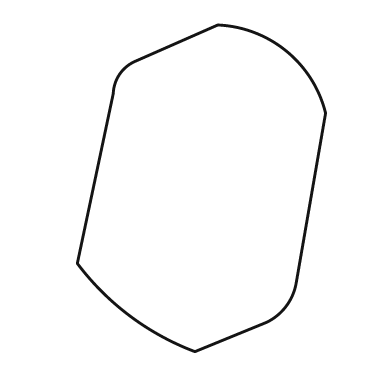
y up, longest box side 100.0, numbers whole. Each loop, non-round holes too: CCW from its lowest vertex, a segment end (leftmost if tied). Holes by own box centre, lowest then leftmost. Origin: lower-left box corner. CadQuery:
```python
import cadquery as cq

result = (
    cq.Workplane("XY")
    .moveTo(36.0, 0.0)
    .lineTo(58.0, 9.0)
    .threePointArc((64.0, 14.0), (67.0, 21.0))
    .lineTo(76.0, 73.0)
    .threePointArc((64.0, 92.0), (43.0, 100.0))
    .lineTo(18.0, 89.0)
    .threePointArc((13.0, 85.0), (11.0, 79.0))
    .lineTo(0.0, 27.0)
    .threePointArc((16.0, 11.0), (36.0, 0.0))
    .close()
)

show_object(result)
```